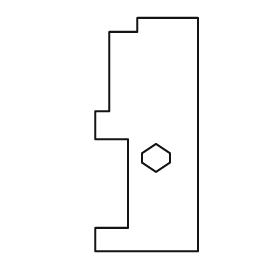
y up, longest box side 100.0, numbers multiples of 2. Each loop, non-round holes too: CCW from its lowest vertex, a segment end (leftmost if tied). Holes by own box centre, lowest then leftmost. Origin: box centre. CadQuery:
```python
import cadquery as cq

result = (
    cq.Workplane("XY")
    .moveTo(-22.0, -50.0)
    .lineTo(22.0, -50.0)
    .lineTo(22.0, 50.0)
    .lineTo(-4.0, 50.0)
    .lineTo(-4.0, 44.0)
    .lineTo(-16.0, 44.0)
    .lineTo(-16.0, 10.0)
    .lineTo(-22.0, 10.0)
    .lineTo(-22.0, -2.0)
    .lineTo(-8.0, -2.0)
    .lineTo(-8.0, -40.0)
    .lineTo(-22.0, -40.0)
    .close()
    .moveTo(4.0, -16.0)
    .lineTo(10.0, -12.0)
    .lineTo(10.0, -8.0)
    .lineTo(4.0, -4.0)
    .lineTo(-2.0, -8.0)
    .lineTo(-2.0, -12.0)
    .close()
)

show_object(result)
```